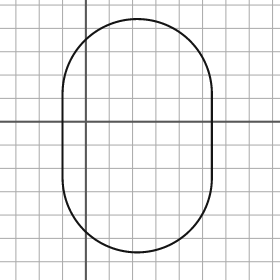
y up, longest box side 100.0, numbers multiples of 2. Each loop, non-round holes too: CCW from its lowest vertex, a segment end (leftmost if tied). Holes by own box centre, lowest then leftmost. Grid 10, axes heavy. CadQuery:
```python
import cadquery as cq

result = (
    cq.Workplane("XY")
    .moveTo(-10.0, -24.0)
    .threePointArc((22.0, -56.0), (54.0, -24.0))
    .lineTo(54.0, 12.0)
    .threePointArc((22.0, 44.0), (-10.0, 12.0))
    .close()
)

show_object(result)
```